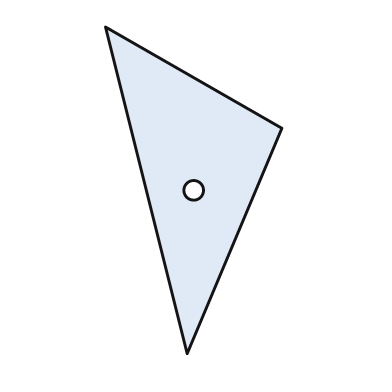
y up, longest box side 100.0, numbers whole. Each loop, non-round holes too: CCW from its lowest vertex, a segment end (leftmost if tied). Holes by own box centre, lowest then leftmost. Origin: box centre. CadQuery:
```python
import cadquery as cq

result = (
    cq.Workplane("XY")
    .moveTo(-2.0, -50.0)
    .lineTo(27.0, 19.0)
    .lineTo(-27.0, 50.0)
    .close()
    .moveTo(0.0, 0.0)
    .circle(3.0)
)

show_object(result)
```